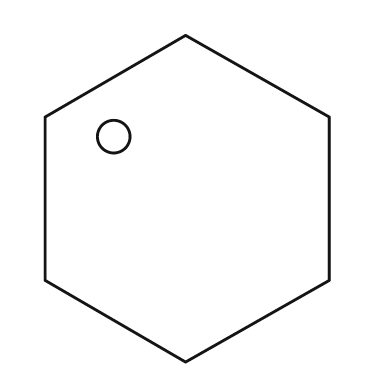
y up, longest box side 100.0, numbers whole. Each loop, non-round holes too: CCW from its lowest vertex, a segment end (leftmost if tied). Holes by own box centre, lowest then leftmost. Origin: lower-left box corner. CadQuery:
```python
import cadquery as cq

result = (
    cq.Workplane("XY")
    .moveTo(43.0, 0.0)
    .lineTo(87.0, 25.0)
    .lineTo(87.0, 75.0)
    .lineTo(43.0, 100.0)
    .lineTo(0.0, 75.0)
    .lineTo(0.0, 25.0)
    .close()
    .moveTo(21.0, 69.0)
    .circle(5.0)
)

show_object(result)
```